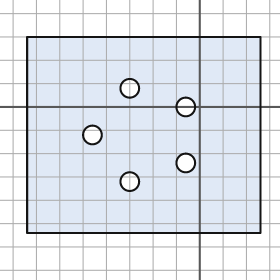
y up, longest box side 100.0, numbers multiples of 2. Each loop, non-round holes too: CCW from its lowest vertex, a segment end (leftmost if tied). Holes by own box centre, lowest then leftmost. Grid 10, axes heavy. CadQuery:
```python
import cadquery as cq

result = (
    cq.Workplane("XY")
    .moveTo(-74.0, -54.0)
    .lineTo(26.0, -54.0)
    .lineTo(26.0, 30.0)
    .lineTo(-74.0, 30.0)
    .close()
    .moveTo(-30.0, -32.0)
    .circle(4.0)
    .moveTo(-6.0, -24.0)
    .circle(4.0)
    .moveTo(-46.0, -12.0)
    .circle(4.0)
    .moveTo(-6.0, 0.0)
    .circle(4.0)
    .moveTo(-30.0, 8.0)
    .circle(4.0)
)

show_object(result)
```